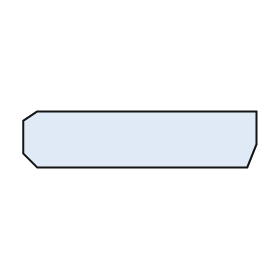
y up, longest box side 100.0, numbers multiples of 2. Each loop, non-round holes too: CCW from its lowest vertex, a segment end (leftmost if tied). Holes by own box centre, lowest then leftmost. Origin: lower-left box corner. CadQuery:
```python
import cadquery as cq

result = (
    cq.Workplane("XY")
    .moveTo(6.0, 0.0)
    .lineTo(96.0, 0.0)
    .lineTo(100.0, 10.0)
    .lineTo(100.0, 24.0)
    .lineTo(6.0, 24.0)
    .lineTo(0.0, 20.0)
    .lineTo(0.0, 6.0)
    .close()
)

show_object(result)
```